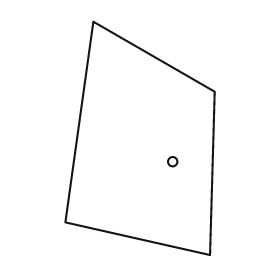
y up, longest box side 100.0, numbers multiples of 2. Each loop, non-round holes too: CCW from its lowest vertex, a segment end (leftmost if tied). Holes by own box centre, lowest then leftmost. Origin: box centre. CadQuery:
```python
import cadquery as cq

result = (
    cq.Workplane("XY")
    .moveTo(30.0, -50.0)
    .lineTo(32.0, 20.0)
    .lineTo(-20.0, 50.0)
    .lineTo(-32.0, -36.0)
    .close()
    .moveTo(14.0, -10.0)
    .circle(2.0)
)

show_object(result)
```